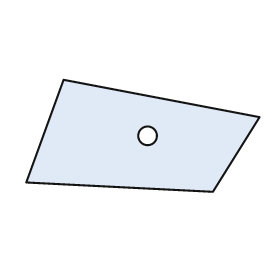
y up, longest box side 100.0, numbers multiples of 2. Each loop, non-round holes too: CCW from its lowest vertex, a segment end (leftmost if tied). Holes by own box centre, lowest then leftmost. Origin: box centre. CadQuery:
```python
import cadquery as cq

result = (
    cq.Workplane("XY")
    .moveTo(30.0, -24.0)
    .lineTo(50.0, 8.0)
    .lineTo(-34.0, 24.0)
    .lineTo(-50.0, -20.0)
    .close()
    .moveTo(2.0, 0.0)
    .circle(4.0)
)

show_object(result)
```